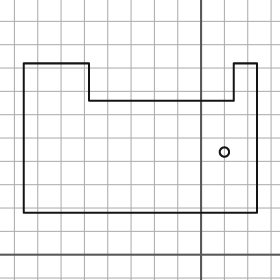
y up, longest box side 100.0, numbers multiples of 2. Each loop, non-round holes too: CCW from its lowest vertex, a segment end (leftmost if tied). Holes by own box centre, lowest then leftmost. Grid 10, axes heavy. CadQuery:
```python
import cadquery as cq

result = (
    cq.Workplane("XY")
    .moveTo(-76.0, 18.0)
    .lineTo(24.0, 18.0)
    .lineTo(24.0, 82.0)
    .lineTo(14.0, 82.0)
    .lineTo(14.0, 66.0)
    .lineTo(-48.0, 66.0)
    .lineTo(-48.0, 82.0)
    .lineTo(-76.0, 82.0)
    .close()
    .moveTo(10.0, 44.0)
    .circle(2.0)
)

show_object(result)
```